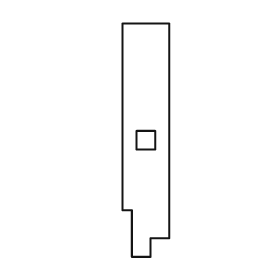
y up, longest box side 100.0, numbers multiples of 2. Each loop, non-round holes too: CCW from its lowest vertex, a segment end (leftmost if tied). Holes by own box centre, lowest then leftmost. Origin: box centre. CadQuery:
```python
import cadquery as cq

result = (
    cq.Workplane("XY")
    .moveTo(-6.0, -50.0)
    .lineTo(2.0, -50.0)
    .lineTo(2.0, -42.0)
    .lineTo(10.0, -42.0)
    .lineTo(10.0, 50.0)
    .lineTo(-10.0, 50.0)
    .lineTo(-10.0, -30.0)
    .lineTo(-6.0, -30.0)
    .close()
    .moveTo(-4.0, -4.0)
    .lineTo(4.0, -4.0)
    .lineTo(4.0, 4.0)
    .lineTo(-4.0, 4.0)
    .close()
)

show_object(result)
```